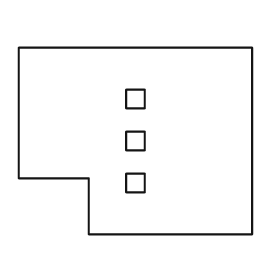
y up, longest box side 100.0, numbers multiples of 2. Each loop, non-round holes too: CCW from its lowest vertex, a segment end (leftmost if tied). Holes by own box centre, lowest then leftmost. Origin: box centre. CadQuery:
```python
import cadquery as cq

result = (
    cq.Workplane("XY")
    .moveTo(-20.0, -40.0)
    .lineTo(50.0, -40.0)
    .lineTo(50.0, 40.0)
    .lineTo(-50.0, 40.0)
    .lineTo(-50.0, -16.0)
    .lineTo(-20.0, -16.0)
    .close()
    .moveTo(-4.0, -22.0)
    .lineTo(4.0, -22.0)
    .lineTo(4.0, -14.0)
    .lineTo(-4.0, -14.0)
    .close()
    .moveTo(-4.0, -4.0)
    .lineTo(4.0, -4.0)
    .lineTo(4.0, 4.0)
    .lineTo(-4.0, 4.0)
    .close()
    .moveTo(-4.0, 14.0)
    .lineTo(4.0, 14.0)
    .lineTo(4.0, 22.0)
    .lineTo(-4.0, 22.0)
    .close()
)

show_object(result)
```